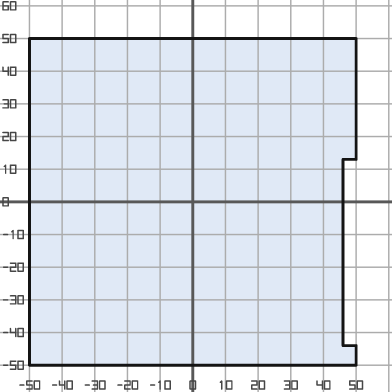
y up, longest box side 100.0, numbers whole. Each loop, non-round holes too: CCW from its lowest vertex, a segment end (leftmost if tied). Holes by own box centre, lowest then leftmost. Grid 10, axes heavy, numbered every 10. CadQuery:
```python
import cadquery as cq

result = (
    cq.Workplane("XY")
    .moveTo(-50.0, -50.0)
    .lineTo(50.0, -50.0)
    .lineTo(50.0, -44.0)
    .lineTo(46.0, -44.0)
    .lineTo(46.0, 13.0)
    .lineTo(50.0, 13.0)
    .lineTo(50.0, 50.0)
    .lineTo(-50.0, 50.0)
    .close()
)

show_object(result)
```